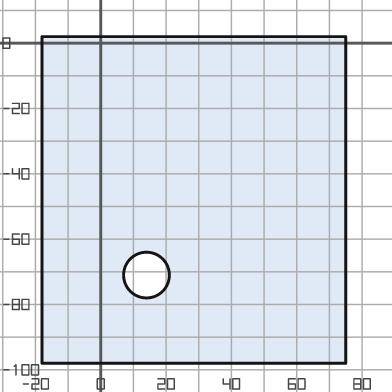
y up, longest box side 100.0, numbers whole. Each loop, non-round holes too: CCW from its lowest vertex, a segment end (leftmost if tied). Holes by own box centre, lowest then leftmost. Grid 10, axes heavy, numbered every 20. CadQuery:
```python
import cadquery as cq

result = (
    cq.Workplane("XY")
    .moveTo(-18.0, -98.0)
    .lineTo(75.0, -98.0)
    .lineTo(75.0, 2.0)
    .lineTo(-18.0, 2.0)
    .close()
    .moveTo(14.0, -71.0)
    .circle(7.0)
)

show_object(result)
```